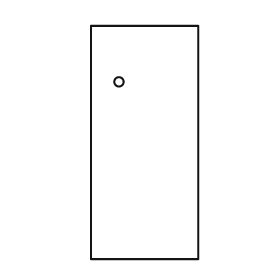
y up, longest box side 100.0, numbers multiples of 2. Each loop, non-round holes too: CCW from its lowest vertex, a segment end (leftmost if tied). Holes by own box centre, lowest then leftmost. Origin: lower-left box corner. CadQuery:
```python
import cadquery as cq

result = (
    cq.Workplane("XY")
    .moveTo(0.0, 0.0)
    .lineTo(46.0, 0.0)
    .lineTo(46.0, 100.0)
    .lineTo(0.0, 100.0)
    .close()
    .moveTo(12.0, 76.0)
    .circle(2.0)
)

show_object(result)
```